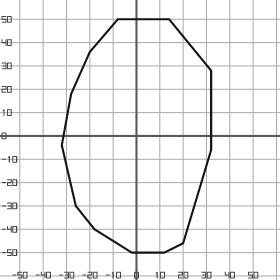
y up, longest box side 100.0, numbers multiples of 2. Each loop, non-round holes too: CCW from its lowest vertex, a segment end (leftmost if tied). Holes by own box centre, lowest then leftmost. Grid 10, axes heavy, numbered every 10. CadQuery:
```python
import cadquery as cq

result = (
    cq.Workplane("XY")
    .moveTo(-2.0, -50.0)
    .lineTo(12.0, -50.0)
    .lineTo(20.0, -46.0)
    .lineTo(32.0, -6.0)
    .lineTo(32.0, 28.0)
    .lineTo(14.0, 50.0)
    .lineTo(-8.0, 50.0)
    .lineTo(-20.0, 36.0)
    .lineTo(-28.0, 18.0)
    .lineTo(-32.0, -4.0)
    .lineTo(-26.0, -30.0)
    .lineTo(-18.0, -40.0)
    .close()
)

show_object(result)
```